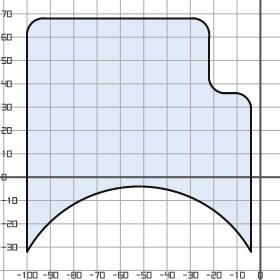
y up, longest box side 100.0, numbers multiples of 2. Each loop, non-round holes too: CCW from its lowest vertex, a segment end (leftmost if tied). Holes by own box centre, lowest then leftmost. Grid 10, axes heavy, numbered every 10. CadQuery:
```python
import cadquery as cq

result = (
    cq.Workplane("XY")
    .moveTo(-100.0, -32.0)
    .threePointArc((-52.0, -4.0), (-4.0, -32.0))
    .lineTo(-4.0, 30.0)
    .threePointArc((-6.0, 34.0), (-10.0, 36.0))
    .lineTo(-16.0, 36.0)
    .threePointArc((-20.0, 38.0), (-22.0, 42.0))
    .lineTo(-22.0, 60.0)
    .threePointArc((-24.0, 66.0), (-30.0, 68.0))
    .lineTo(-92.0, 68.0)
    .threePointArc((-98.0, 66.0), (-100.0, 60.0))
    .close()
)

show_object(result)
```